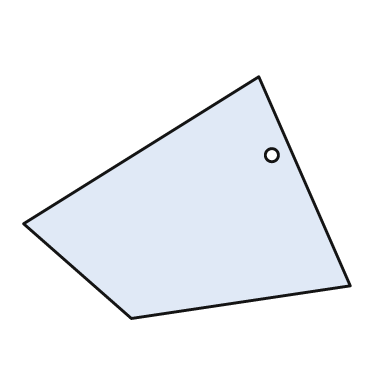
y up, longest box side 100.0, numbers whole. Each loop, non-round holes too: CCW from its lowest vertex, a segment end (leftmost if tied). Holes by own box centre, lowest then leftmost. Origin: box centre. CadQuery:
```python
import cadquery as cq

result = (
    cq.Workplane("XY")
    .moveTo(-17.0, -37.0)
    .lineTo(50.0, -27.0)
    .lineTo(22.0, 37.0)
    .lineTo(-50.0, -8.0)
    .close()
    .moveTo(26.0, 13.0)
    .circle(2.0)
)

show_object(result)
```